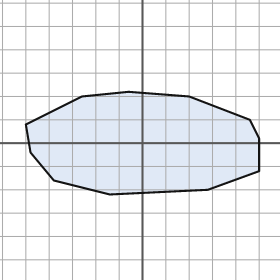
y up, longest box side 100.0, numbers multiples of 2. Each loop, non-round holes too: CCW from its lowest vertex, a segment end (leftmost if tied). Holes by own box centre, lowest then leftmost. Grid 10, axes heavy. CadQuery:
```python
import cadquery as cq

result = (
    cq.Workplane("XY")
    .moveTo(-14.0, -22.0)
    .lineTo(28.0, -20.0)
    .lineTo(50.0, -12.0)
    .lineTo(50.0, 2.0)
    .lineTo(46.0, 10.0)
    .lineTo(20.0, 20.0)
    .lineTo(-6.0, 22.0)
    .lineTo(-26.0, 20.0)
    .lineTo(-50.0, 8.0)
    .lineTo(-48.0, -4.0)
    .lineTo(-38.0, -16.0)
    .close()
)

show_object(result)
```